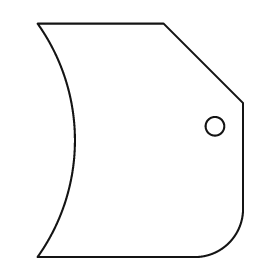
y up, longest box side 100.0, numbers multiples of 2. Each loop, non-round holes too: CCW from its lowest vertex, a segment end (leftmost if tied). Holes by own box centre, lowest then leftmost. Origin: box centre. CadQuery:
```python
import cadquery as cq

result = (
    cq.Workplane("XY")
    .moveTo(-44.0, -50.0)
    .lineTo(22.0, -50.0)
    .threePointArc((38.0, -44.0), (44.0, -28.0))
    .lineTo(44.0, 16.0)
    .lineTo(10.0, 50.0)
    .lineTo(-44.0, 50.0)
    .threePointArc((-28.0, 0.0), (-44.0, -50.0))
    .close()
    .moveTo(32.0, 6.0)
    .circle(4.0)
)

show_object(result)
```